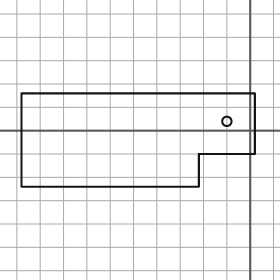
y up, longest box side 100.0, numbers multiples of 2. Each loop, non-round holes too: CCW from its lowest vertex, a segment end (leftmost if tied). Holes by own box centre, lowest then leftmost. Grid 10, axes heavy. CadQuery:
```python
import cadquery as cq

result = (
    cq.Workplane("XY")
    .moveTo(-98.0, -24.0)
    .lineTo(-22.0, -24.0)
    .lineTo(-22.0, -10.0)
    .lineTo(2.0, -10.0)
    .lineTo(2.0, 16.0)
    .lineTo(-98.0, 16.0)
    .close()
    .moveTo(-10.0, 4.0)
    .circle(2.0)
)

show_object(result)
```